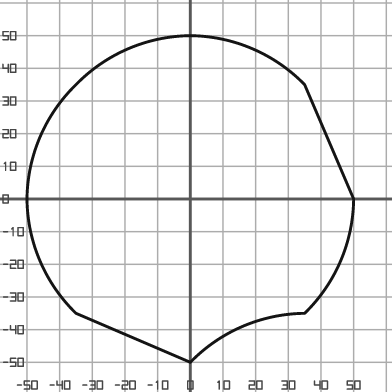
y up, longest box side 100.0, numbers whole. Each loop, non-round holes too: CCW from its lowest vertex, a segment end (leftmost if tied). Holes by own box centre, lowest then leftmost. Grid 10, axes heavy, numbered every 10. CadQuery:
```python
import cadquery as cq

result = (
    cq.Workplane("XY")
    .moveTo(0.0, -50.0)
    .threePointArc((16.0, -39.0), (35.0, -35.0))
    .threePointArc((46.0, -19.0), (50.0, 0.0))
    .lineTo(35.0, 35.0)
    .threePointArc((19.0, 46.0), (0.0, 50.0))
    .threePointArc((-19.0, 46.0), (-35.0, 35.0))
    .threePointArc((-46.0, 19.0), (-50.0, 0.0))
    .threePointArc((-46.0, -19.0), (-35.0, -35.0))
    .close()
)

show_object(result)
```